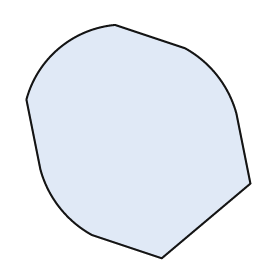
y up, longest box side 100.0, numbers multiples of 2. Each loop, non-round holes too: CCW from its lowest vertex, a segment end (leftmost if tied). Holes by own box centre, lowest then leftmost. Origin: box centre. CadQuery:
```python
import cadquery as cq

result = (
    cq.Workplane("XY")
    .moveTo(10.0, -50.0)
    .lineTo(48.0, -18.0)
    .lineTo(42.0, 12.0)
    .threePointArc((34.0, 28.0), (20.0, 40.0))
    .lineTo(-10.0, 50.0)
    .threePointArc((-34.0, 40.0), (-48.0, 18.0))
    .lineTo(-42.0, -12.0)
    .threePointArc((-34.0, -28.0), (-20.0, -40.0))
    .close()
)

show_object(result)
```